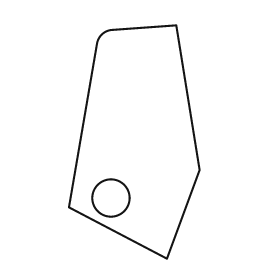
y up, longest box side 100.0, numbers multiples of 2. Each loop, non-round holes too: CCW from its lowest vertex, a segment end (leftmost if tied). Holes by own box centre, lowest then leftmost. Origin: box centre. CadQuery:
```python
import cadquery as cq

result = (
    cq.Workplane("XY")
    .moveTo(14.0, -50.0)
    .lineTo(28.0, -12.0)
    .lineTo(18.0, 50.0)
    .lineTo(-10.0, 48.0)
    .threePointArc((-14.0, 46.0), (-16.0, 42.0))
    .lineTo(-28.0, -28.0)
    .close()
    .moveTo(-10.0, -24.0)
    .circle(8.0)
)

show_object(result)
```